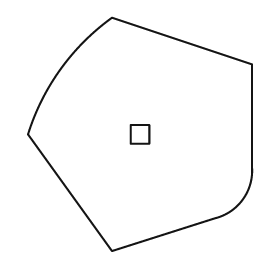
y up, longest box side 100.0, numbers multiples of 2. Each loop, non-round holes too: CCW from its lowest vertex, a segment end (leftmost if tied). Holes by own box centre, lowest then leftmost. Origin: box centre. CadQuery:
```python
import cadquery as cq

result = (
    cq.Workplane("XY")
    .moveTo(-12.0, -50.0)
    .lineTo(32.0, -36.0)
    .threePointArc((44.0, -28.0), (48.0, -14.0))
    .lineTo(48.0, 30.0)
    .lineTo(-12.0, 50.0)
    .threePointArc((-34.0, 28.0), (-48.0, 0.0))
    .close()
    .moveTo(-4.0, -4.0)
    .lineTo(4.0, -4.0)
    .lineTo(4.0, 4.0)
    .lineTo(-4.0, 4.0)
    .close()
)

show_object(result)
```